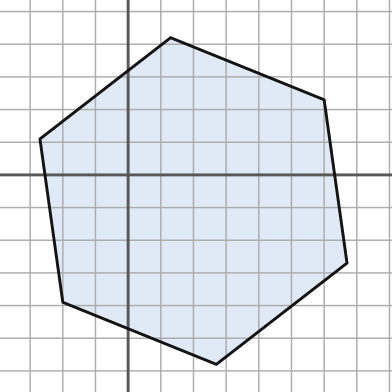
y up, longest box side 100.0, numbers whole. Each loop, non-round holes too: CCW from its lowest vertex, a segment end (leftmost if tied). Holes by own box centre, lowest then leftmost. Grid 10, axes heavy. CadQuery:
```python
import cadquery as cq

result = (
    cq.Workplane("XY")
    .moveTo(27.0, -58.0)
    .lineTo(67.0, -27.0)
    .lineTo(60.0, 23.0)
    .lineTo(13.0, 42.0)
    .lineTo(-27.0, 11.0)
    .lineTo(-20.0, -39.0)
    .close()
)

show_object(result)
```